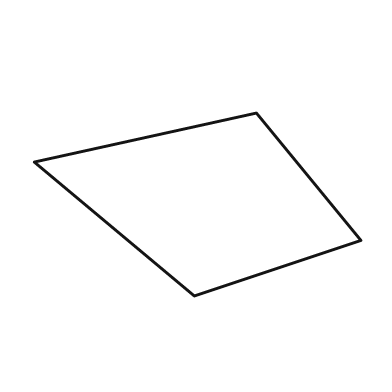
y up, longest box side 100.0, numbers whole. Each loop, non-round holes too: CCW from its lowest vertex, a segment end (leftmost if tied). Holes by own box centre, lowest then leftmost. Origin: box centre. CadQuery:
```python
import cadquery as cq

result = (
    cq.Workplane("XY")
    .moveTo(-1.0, -28.0)
    .lineTo(50.0, -11.0)
    .lineTo(18.0, 28.0)
    .lineTo(-50.0, 13.0)
    .close()
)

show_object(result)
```